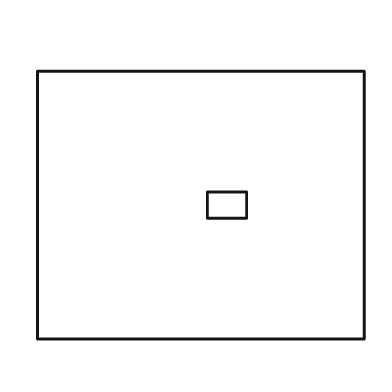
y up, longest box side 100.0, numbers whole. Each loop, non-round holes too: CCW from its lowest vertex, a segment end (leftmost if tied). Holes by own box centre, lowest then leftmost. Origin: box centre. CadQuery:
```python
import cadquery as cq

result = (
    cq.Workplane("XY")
    .moveTo(-50.0, -41.0)
    .lineTo(50.0, -41.0)
    .lineTo(50.0, 41.0)
    .lineTo(-50.0, 41.0)
    .close()
    .moveTo(2.0, -4.0)
    .lineTo(14.0, -4.0)
    .lineTo(14.0, 4.0)
    .lineTo(2.0, 4.0)
    .close()
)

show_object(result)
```